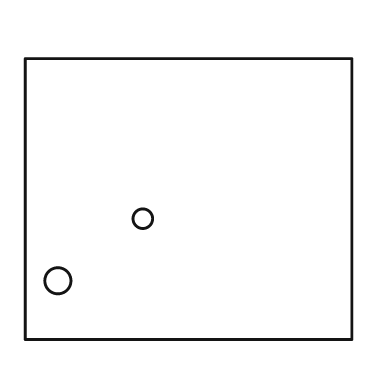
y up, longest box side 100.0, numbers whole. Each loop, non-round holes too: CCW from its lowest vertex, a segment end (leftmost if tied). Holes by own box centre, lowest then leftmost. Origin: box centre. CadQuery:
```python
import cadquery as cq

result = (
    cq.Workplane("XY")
    .moveTo(-50.0, -43.0)
    .lineTo(50.0, -43.0)
    .lineTo(50.0, 43.0)
    .lineTo(-50.0, 43.0)
    .close()
    .moveTo(-40.0, -25.0)
    .circle(4.0)
    .moveTo(-14.0, -6.0)
    .circle(3.0)
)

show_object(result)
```